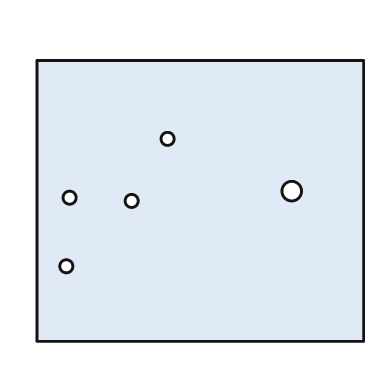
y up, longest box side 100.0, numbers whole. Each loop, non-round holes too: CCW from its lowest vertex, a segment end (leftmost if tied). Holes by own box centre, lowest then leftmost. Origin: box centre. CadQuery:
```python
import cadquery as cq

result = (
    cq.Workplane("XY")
    .moveTo(-50.0, -43.0)
    .lineTo(50.0, -43.0)
    .lineTo(50.0, 43.0)
    .lineTo(-50.0, 43.0)
    .close()
    .moveTo(-41.0, -20.0)
    .circle(2.0)
    .moveTo(-21.0, 0.0)
    .circle(2.0)
    .moveTo(-40.0, 1.0)
    .circle(2.0)
    .moveTo(28.0, 3.0)
    .circle(3.0)
    .moveTo(-10.0, 19.0)
    .circle(2.0)
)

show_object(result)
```